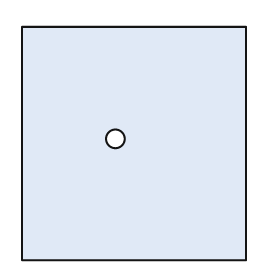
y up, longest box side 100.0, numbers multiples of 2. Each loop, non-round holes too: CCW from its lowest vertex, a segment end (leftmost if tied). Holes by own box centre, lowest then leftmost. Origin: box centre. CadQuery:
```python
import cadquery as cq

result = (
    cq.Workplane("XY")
    .moveTo(-48.0, -50.0)
    .lineTo(48.0, -50.0)
    .lineTo(48.0, 50.0)
    .lineTo(-48.0, 50.0)
    .close()
    .moveTo(-8.0, 2.0)
    .circle(4.0)
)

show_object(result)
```